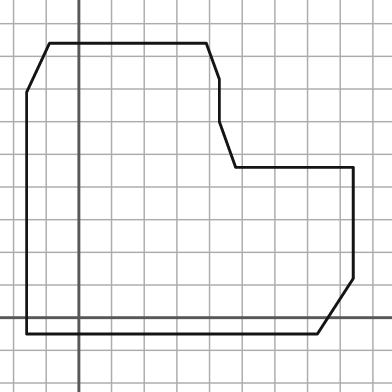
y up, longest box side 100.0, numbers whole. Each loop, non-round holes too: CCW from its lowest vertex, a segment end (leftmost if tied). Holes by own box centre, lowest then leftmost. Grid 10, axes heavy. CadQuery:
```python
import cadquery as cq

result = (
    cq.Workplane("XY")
    .moveTo(-16.0, -5.0)
    .lineTo(73.0, -5.0)
    .lineTo(84.0, 12.0)
    .lineTo(84.0, 46.0)
    .lineTo(48.0, 46.0)
    .lineTo(43.0, 60.0)
    .lineTo(43.0, 73.0)
    .lineTo(39.0, 84.0)
    .lineTo(-9.0, 84.0)
    .lineTo(-16.0, 69.0)
    .close()
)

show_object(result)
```